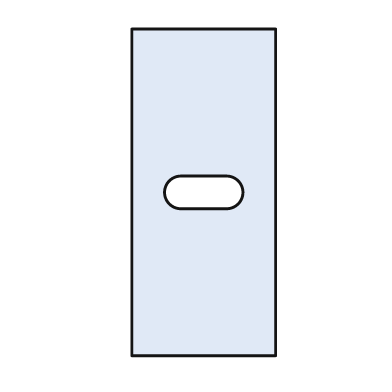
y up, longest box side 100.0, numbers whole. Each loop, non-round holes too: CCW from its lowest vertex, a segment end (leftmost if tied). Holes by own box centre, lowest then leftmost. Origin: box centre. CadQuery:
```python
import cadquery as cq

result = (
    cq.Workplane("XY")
    .moveTo(-22.0, -50.0)
    .lineTo(22.0, -50.0)
    .lineTo(22.0, 50.0)
    .lineTo(-22.0, 50.0)
    .close()
    .moveTo(-7.0, -5.0)
    .lineTo(7.0, -5.0)
    .threePointArc((12.0, 0.0), (7.0, 5.0))
    .lineTo(-7.0, 5.0)
    .threePointArc((-12.0, 0.0), (-7.0, -5.0))
    .close()
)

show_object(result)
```